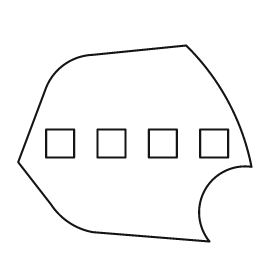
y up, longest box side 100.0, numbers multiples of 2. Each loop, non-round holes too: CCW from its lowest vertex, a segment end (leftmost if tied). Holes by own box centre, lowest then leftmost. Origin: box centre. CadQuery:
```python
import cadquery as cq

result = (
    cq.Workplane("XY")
    .moveTo(32.0, -42.0)
    .threePointArc((30.0, -20.0), (50.0, -10.0))
    .threePointArc((40.0, 18.0), (22.0, 42.0))
    .lineTo(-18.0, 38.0)
    .threePointArc((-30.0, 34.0), (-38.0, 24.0))
    .lineTo(-50.0, -8.0)
    .lineTo(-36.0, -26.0)
    .threePointArc((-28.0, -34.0), (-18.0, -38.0))
    .close()
    .moveTo(-38.0, -6.0)
    .lineTo(-26.0, -6.0)
    .lineTo(-26.0, 6.0)
    .lineTo(-38.0, 6.0)
    .close()
    .moveTo(-16.0, -6.0)
    .lineTo(-4.0, -6.0)
    .lineTo(-4.0, 6.0)
    .lineTo(-16.0, 6.0)
    .close()
    .moveTo(6.0, -6.0)
    .lineTo(18.0, -6.0)
    .lineTo(18.0, 6.0)
    .lineTo(6.0, 6.0)
    .close()
    .moveTo(28.0, -6.0)
    .lineTo(40.0, -6.0)
    .lineTo(40.0, 6.0)
    .lineTo(28.0, 6.0)
    .close()
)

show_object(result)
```